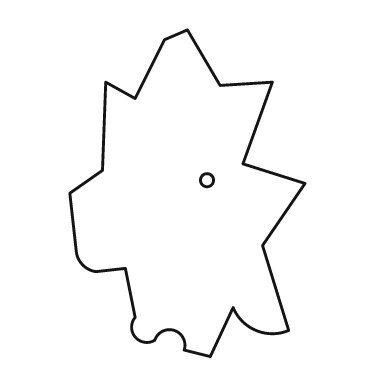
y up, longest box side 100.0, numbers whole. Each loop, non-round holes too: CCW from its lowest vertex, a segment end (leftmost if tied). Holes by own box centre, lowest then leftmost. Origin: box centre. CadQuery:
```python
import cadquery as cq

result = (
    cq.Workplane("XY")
    .moveTo(7.0, -50.0)
    .lineTo(14.0, -35.0)
    .threePointArc((21.0, -42.0), (31.0, -42.0))
    .lineTo(23.0, -16.0)
    .lineTo(36.0, 3.0)
    .lineTo(17.0, 9.0)
    .lineTo(26.0, 34.0)
    .lineTo(10.0, 33.0)
    .lineTo(0.0, 50.0)
    .lineTo(-7.0, 47.0)
    .lineTo(-16.0, 29.0)
    .lineTo(-25.0, 34.0)
    .lineTo(-26.0, 7.0)
    .lineTo(-36.0, 0.0)
    .lineTo(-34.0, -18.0)
    .threePointArc((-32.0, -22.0), (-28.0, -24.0))
    .lineTo(-19.0, -23.0)
    .lineTo(-16.0, -38.0)
    .threePointArc((-16.0, -44.0), (-10.0, -45.0))
    .threePointArc((-4.0, -42.0), (-1.0, -48.0))
    .close()
    .moveTo(6.0, 4.0)
    .circle(2.0)
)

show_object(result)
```